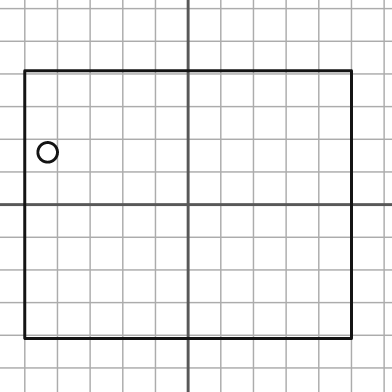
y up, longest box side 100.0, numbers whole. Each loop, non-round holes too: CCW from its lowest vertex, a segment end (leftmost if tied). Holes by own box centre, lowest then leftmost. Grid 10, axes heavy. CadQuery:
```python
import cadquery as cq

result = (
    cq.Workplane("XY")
    .moveTo(-50.0, -41.0)
    .lineTo(50.0, -41.0)
    .lineTo(50.0, 41.0)
    .lineTo(-50.0, 41.0)
    .close()
    .moveTo(-43.0, 16.0)
    .circle(3.0)
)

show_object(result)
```